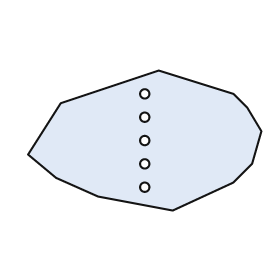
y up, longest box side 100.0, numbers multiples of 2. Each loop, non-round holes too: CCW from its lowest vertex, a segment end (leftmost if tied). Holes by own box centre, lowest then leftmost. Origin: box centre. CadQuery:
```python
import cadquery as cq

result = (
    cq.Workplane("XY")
    .moveTo(12.0, -30.0)
    .lineTo(38.0, -18.0)
    .lineTo(46.0, -10.0)
    .lineTo(50.0, 4.0)
    .lineTo(44.0, 14.0)
    .lineTo(38.0, 20.0)
    .lineTo(6.0, 30.0)
    .lineTo(-36.0, 16.0)
    .lineTo(-50.0, -6.0)
    .lineTo(-38.0, -16.0)
    .lineTo(-20.0, -24.0)
    .close()
    .moveTo(0.0, -20.0)
    .circle(2.0)
    .moveTo(0.0, -10.0)
    .circle(2.0)
    .moveTo(0.0, 0.0)
    .circle(2.0)
    .moveTo(0.0, 10.0)
    .circle(2.0)
    .moveTo(0.0, 20.0)
    .circle(2.0)
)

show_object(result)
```